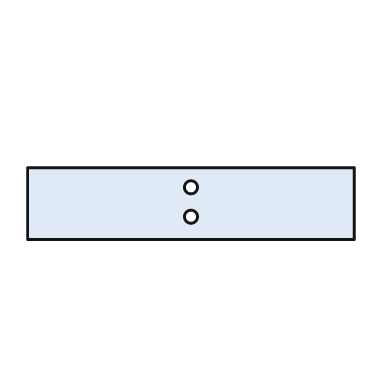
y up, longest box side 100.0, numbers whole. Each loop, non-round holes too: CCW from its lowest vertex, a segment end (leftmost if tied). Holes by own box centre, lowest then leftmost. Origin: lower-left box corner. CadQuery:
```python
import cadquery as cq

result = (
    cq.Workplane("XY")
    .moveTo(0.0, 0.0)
    .lineTo(100.0, 0.0)
    .lineTo(100.0, 22.0)
    .lineTo(0.0, 22.0)
    .close()
    .moveTo(50.0, 7.0)
    .circle(2.0)
    .moveTo(50.0, 16.0)
    .circle(2.0)
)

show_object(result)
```